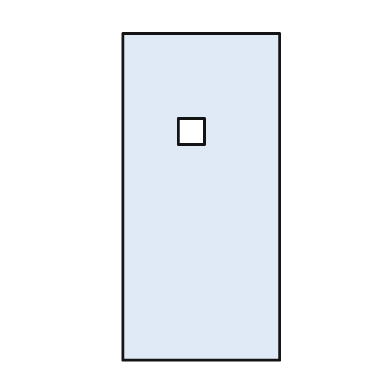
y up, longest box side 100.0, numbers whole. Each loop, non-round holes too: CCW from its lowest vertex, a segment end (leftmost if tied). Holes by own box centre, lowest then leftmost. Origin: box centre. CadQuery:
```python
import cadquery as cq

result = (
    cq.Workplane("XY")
    .moveTo(-24.0, -50.0)
    .lineTo(24.0, -50.0)
    .lineTo(24.0, 50.0)
    .lineTo(-24.0, 50.0)
    .close()
    .moveTo(-7.0, 16.0)
    .lineTo(1.0, 16.0)
    .lineTo(1.0, 24.0)
    .lineTo(-7.0, 24.0)
    .close()
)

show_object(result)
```